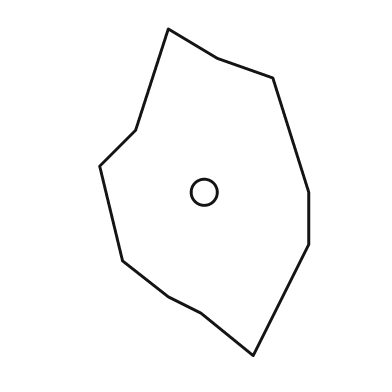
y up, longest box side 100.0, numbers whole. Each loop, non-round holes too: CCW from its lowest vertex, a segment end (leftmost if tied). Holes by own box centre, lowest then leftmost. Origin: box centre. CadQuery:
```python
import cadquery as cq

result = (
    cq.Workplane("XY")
    .moveTo(15.0, -50.0)
    .lineTo(32.0, -16.0)
    .lineTo(32.0, 0.0)
    .lineTo(21.0, 35.0)
    .lineTo(4.0, 41.0)
    .lineTo(-11.0, 50.0)
    .lineTo(-21.0, 19.0)
    .lineTo(-32.0, 8.0)
    .lineTo(-25.0, -21.0)
    .lineTo(-11.0, -32.0)
    .lineTo(-1.0, -37.0)
    .close()
    .moveTo(0.0, 0.0)
    .circle(4.0)
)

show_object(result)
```